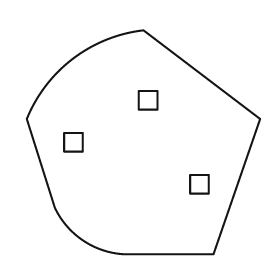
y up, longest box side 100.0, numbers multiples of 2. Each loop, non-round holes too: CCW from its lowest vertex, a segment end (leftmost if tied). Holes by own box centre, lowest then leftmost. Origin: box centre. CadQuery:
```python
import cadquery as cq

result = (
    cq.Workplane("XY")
    .moveTo(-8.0, -48.0)
    .lineTo(30.0, -48.0)
    .lineTo(50.0, 10.0)
    .lineTo(0.0, 48.0)
    .threePointArc((-30.0, 36.0), (-50.0, 10.0))
    .lineTo(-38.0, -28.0)
    .threePointArc((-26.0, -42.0), (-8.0, -48.0))
    .close()
    .moveTo(20.0, -22.0)
    .lineTo(28.0, -22.0)
    .lineTo(28.0, -14.0)
    .lineTo(20.0, -14.0)
    .close()
    .moveTo(-34.0, -4.0)
    .lineTo(-26.0, -4.0)
    .lineTo(-26.0, 4.0)
    .lineTo(-34.0, 4.0)
    .close()
    .moveTo(-2.0, 14.0)
    .lineTo(6.0, 14.0)
    .lineTo(6.0, 22.0)
    .lineTo(-2.0, 22.0)
    .close()
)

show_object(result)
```